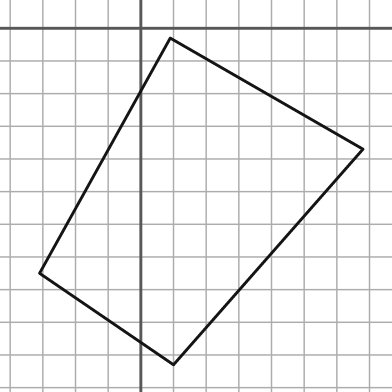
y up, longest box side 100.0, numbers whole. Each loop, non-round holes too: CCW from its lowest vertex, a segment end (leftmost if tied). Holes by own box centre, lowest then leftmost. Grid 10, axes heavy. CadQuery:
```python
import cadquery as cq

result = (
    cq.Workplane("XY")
    .moveTo(10.0, -103.0)
    .lineTo(68.0, -37.0)
    .lineTo(9.0, -3.0)
    .lineTo(-31.0, -75.0)
    .close()
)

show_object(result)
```